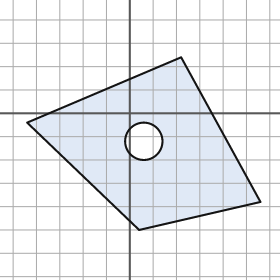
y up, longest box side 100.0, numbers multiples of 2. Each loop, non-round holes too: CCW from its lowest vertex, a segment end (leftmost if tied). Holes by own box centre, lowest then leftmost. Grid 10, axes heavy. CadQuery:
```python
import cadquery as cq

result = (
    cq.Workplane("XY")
    .moveTo(4.0, -50.0)
    .lineTo(56.0, -38.0)
    .lineTo(22.0, 24.0)
    .lineTo(-44.0, -4.0)
    .close()
    .moveTo(6.0, -12.0)
    .circle(8.0)
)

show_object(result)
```